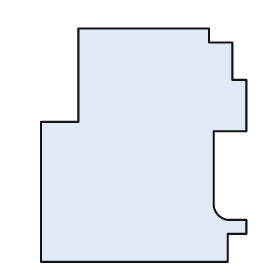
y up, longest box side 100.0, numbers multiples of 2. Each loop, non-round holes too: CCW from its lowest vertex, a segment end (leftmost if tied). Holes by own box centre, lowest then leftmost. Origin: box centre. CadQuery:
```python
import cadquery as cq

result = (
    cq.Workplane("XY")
    .moveTo(-44.0, -50.0)
    .lineTo(36.0, -50.0)
    .lineTo(36.0, -38.0)
    .lineTo(44.0, -38.0)
    .lineTo(44.0, -32.0)
    .lineTo(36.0, -32.0)
    .threePointArc((32.0, -30.0), (30.0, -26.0))
    .lineTo(30.0, 6.0)
    .lineTo(44.0, 6.0)
    .lineTo(44.0, 28.0)
    .lineTo(38.0, 28.0)
    .lineTo(38.0, 44.0)
    .lineTo(28.0, 44.0)
    .lineTo(28.0, 50.0)
    .lineTo(-28.0, 50.0)
    .lineTo(-28.0, 10.0)
    .lineTo(-44.0, 10.0)
    .close()
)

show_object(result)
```